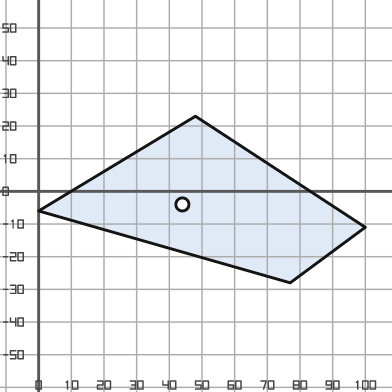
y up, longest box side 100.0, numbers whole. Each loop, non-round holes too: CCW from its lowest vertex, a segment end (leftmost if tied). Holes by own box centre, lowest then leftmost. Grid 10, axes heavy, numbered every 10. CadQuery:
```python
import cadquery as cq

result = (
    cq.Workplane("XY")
    .moveTo(77.0, -28.0)
    .lineTo(100.0, -11.0)
    .lineTo(48.0, 23.0)
    .lineTo(0.0, -6.0)
    .close()
    .moveTo(44.0, -4.0)
    .circle(2.0)
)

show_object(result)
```